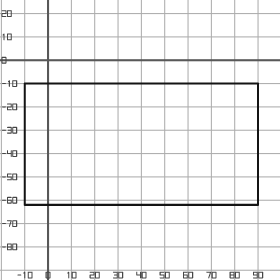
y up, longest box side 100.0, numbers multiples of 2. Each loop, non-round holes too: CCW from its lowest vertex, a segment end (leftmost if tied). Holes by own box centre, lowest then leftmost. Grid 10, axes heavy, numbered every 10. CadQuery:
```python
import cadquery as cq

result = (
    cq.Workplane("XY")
    .moveTo(-10.0, -62.0)
    .lineTo(90.0, -62.0)
    .lineTo(90.0, -10.0)
    .lineTo(-10.0, -10.0)
    .close()
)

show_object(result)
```